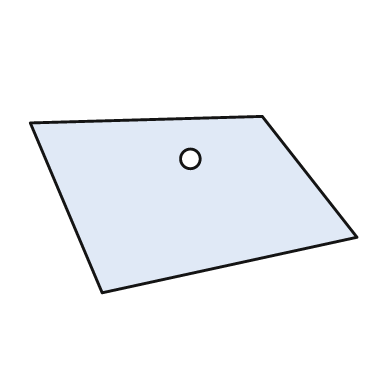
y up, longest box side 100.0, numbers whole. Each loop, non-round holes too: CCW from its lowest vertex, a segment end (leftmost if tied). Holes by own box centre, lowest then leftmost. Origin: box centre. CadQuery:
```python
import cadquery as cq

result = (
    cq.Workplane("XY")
    .moveTo(-28.0, -27.0)
    .lineTo(50.0, -10.0)
    .lineTo(21.0, 27.0)
    .lineTo(-50.0, 25.0)
    .close()
    .moveTo(-1.0, 14.0)
    .circle(3.0)
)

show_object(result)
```